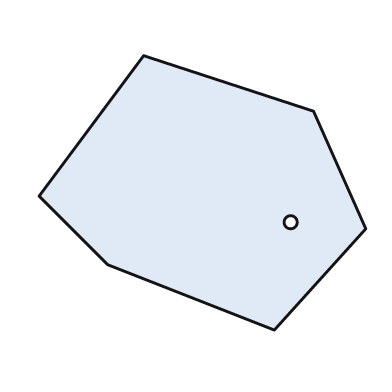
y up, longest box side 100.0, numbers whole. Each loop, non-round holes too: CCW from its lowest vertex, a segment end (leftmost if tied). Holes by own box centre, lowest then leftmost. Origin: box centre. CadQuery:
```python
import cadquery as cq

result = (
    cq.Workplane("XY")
    .moveTo(22.0, -42.0)
    .lineTo(50.0, -11.0)
    .lineTo(34.0, 25.0)
    .lineTo(-18.0, 42.0)
    .lineTo(-50.0, -1.0)
    .lineTo(-29.0, -22.0)
    .close()
    .moveTo(27.0, -9.0)
    .circle(2.0)
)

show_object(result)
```